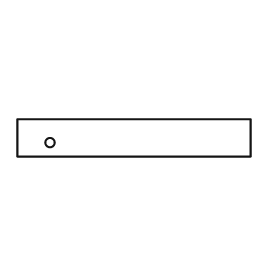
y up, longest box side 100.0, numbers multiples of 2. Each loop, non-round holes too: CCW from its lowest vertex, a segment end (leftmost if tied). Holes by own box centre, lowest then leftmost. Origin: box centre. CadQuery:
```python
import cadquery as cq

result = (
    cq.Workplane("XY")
    .moveTo(-50.0, -8.0)
    .lineTo(50.0, -8.0)
    .lineTo(50.0, 8.0)
    .lineTo(-50.0, 8.0)
    .close()
    .moveTo(-36.0, -2.0)
    .circle(2.0)
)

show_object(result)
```